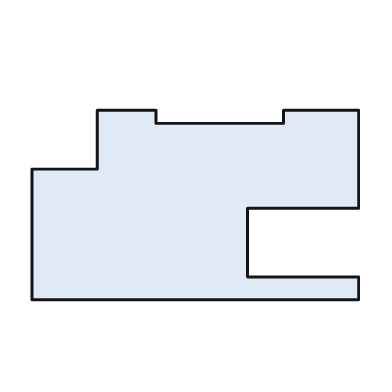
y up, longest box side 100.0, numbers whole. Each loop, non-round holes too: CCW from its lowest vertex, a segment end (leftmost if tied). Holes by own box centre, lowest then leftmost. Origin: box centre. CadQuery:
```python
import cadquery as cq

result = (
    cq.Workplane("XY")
    .moveTo(-50.0, -29.0)
    .lineTo(50.0, -29.0)
    .lineTo(50.0, -22.0)
    .lineTo(16.0, -22.0)
    .lineTo(16.0, -1.0)
    .lineTo(50.0, -1.0)
    .lineTo(50.0, 29.0)
    .lineTo(27.0, 29.0)
    .lineTo(27.0, 25.0)
    .lineTo(-12.0, 25.0)
    .lineTo(-12.0, 29.0)
    .lineTo(-30.0, 29.0)
    .lineTo(-30.0, 11.0)
    .lineTo(-50.0, 11.0)
    .close()
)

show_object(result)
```